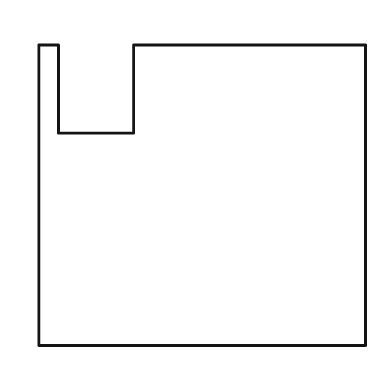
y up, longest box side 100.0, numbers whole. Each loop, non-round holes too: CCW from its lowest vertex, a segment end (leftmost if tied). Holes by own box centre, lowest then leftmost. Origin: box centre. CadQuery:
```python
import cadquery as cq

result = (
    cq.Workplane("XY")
    .moveTo(-50.0, -46.0)
    .lineTo(50.0, -46.0)
    .lineTo(50.0, 46.0)
    .lineTo(-21.0, 46.0)
    .lineTo(-21.0, 19.0)
    .lineTo(-44.0, 19.0)
    .lineTo(-44.0, 46.0)
    .lineTo(-50.0, 46.0)
    .close()
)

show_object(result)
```